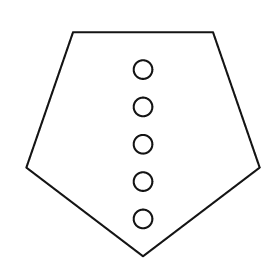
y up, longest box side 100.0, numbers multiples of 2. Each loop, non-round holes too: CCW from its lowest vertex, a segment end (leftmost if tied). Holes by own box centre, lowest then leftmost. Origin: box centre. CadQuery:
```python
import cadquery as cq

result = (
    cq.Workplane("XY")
    .moveTo(0.0, -48.0)
    .lineTo(50.0, -10.0)
    .lineTo(30.0, 48.0)
    .lineTo(-30.0, 48.0)
    .lineTo(-50.0, -10.0)
    .close()
    .moveTo(0.0, -32.0)
    .circle(4.0)
    .moveTo(0.0, -16.0)
    .circle(4.0)
    .moveTo(0.0, 0.0)
    .circle(4.0)
    .moveTo(0.0, 16.0)
    .circle(4.0)
    .moveTo(0.0, 32.0)
    .circle(4.0)
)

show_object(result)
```